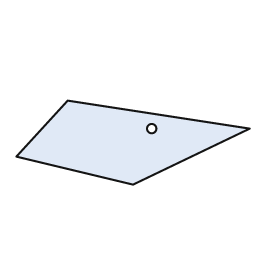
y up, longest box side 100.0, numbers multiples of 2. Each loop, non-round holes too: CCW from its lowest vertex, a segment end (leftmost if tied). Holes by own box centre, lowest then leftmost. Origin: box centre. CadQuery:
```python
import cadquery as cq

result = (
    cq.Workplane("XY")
    .moveTo(0.0, -18.0)
    .lineTo(50.0, 6.0)
    .lineTo(-28.0, 18.0)
    .lineTo(-50.0, -6.0)
    .close()
    .moveTo(8.0, 6.0)
    .circle(2.0)
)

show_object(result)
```